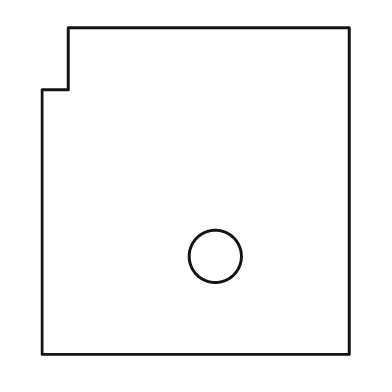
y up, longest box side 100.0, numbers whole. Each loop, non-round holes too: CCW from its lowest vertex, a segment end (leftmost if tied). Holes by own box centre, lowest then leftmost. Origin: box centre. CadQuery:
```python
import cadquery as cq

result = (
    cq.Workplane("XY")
    .moveTo(-47.0, -50.0)
    .lineTo(47.0, -50.0)
    .lineTo(47.0, 50.0)
    .lineTo(-39.0, 50.0)
    .lineTo(-39.0, 31.0)
    .lineTo(-47.0, 31.0)
    .close()
    .moveTo(6.0, -20.0)
    .circle(8.0)
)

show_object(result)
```